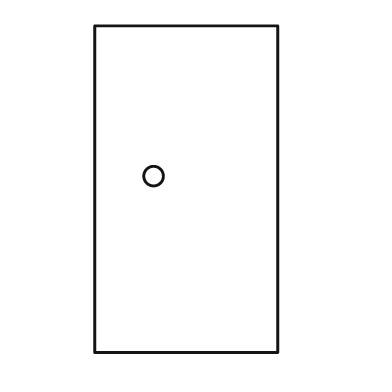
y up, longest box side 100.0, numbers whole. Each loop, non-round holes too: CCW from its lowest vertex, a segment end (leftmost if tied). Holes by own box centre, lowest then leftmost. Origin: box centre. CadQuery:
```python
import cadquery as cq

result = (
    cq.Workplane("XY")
    .moveTo(-28.0, -50.0)
    .lineTo(28.0, -50.0)
    .lineTo(28.0, 50.0)
    .lineTo(-28.0, 50.0)
    .close()
    .moveTo(-10.0, 4.0)
    .circle(3.0)
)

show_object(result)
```